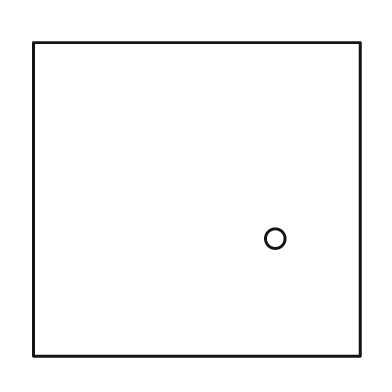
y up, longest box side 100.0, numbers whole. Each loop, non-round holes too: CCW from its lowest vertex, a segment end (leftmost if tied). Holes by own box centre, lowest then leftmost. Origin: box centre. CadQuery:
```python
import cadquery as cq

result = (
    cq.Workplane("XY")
    .moveTo(-50.0, -48.0)
    .lineTo(50.0, -48.0)
    .lineTo(50.0, 48.0)
    .lineTo(-50.0, 48.0)
    .close()
    .moveTo(24.0, -12.0)
    .circle(3.0)
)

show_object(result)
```